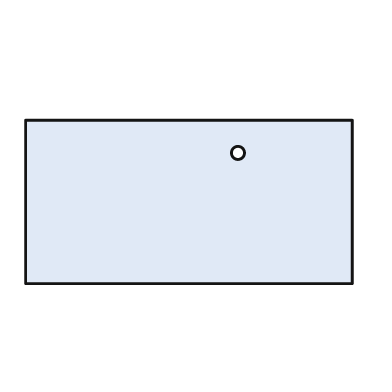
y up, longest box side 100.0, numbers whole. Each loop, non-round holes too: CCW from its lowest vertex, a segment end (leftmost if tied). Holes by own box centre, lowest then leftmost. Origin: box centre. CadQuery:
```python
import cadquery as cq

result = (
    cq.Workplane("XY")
    .moveTo(-50.0, -25.0)
    .lineTo(50.0, -25.0)
    .lineTo(50.0, 25.0)
    .lineTo(-50.0, 25.0)
    .close()
    .moveTo(15.0, 15.0)
    .circle(2.0)
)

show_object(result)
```